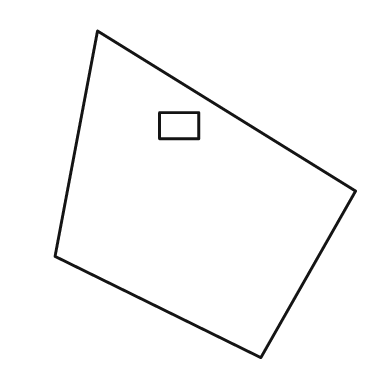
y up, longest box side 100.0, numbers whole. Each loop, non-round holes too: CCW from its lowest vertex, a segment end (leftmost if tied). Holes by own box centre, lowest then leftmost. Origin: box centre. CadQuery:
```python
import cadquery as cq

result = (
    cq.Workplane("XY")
    .moveTo(17.0, -50.0)
    .lineTo(46.0, 1.0)
    .lineTo(-33.0, 50.0)
    .lineTo(-46.0, -19.0)
    .close()
    .moveTo(-14.0, 17.0)
    .lineTo(-2.0, 17.0)
    .lineTo(-2.0, 25.0)
    .lineTo(-14.0, 25.0)
    .close()
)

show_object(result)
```